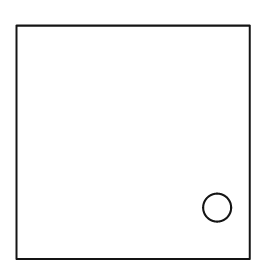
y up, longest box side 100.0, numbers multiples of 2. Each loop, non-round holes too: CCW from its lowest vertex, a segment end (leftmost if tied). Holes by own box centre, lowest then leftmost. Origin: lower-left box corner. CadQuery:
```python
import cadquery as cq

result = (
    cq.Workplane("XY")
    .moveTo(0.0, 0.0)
    .lineTo(100.0, 0.0)
    .lineTo(100.0, 100.0)
    .lineTo(0.0, 100.0)
    .close()
    .moveTo(86.0, 22.0)
    .circle(6.0)
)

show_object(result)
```